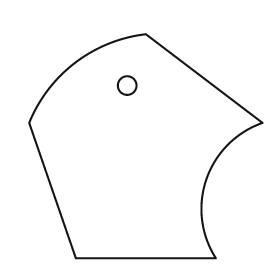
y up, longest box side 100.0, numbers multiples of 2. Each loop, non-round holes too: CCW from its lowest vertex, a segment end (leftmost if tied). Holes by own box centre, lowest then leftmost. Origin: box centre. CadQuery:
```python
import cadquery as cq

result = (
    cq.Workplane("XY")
    .moveTo(-30.0, -48.0)
    .lineTo(30.0, -48.0)
    .threePointArc((26.0, -14.0), (50.0, 10.0))
    .lineTo(0.0, 48.0)
    .threePointArc((-30.0, 36.0), (-50.0, 10.0))
    .close()
    .moveTo(-8.0, 26.0)
    .circle(4.0)
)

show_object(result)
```